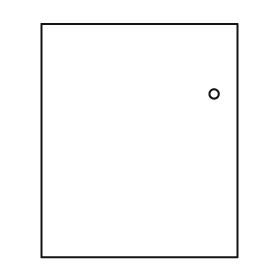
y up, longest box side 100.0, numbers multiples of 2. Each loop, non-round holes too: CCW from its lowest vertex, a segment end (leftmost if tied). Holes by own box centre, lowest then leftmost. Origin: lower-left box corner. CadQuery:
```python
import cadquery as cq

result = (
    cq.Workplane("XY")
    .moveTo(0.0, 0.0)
    .lineTo(84.0, 0.0)
    .lineTo(84.0, 100.0)
    .lineTo(0.0, 100.0)
    .close()
    .moveTo(74.0, 70.0)
    .circle(2.0)
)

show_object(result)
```